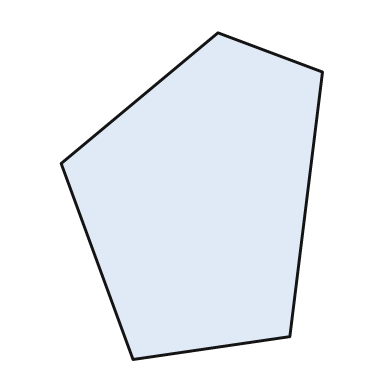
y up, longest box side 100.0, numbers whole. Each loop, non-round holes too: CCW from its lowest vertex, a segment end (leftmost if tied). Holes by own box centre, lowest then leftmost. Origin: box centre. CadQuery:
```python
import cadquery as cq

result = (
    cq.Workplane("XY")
    .moveTo(-18.0, -50.0)
    .lineTo(30.0, -43.0)
    .lineTo(40.0, 38.0)
    .lineTo(8.0, 50.0)
    .lineTo(-40.0, 10.0)
    .close()
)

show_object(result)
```